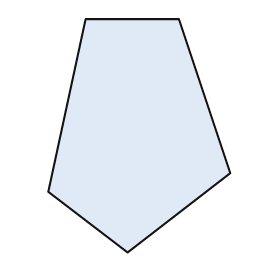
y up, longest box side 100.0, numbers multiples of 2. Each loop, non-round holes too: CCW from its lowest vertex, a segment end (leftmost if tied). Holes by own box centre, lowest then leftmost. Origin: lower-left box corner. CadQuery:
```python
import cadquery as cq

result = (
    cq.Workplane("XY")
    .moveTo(34.0, 0.0)
    .lineTo(78.0, 34.0)
    .lineTo(56.0, 100.0)
    .lineTo(16.0, 100.0)
    .lineTo(0.0, 26.0)
    .close()
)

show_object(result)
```